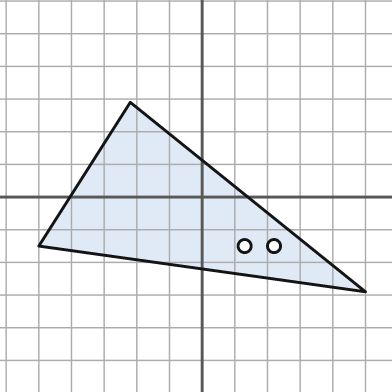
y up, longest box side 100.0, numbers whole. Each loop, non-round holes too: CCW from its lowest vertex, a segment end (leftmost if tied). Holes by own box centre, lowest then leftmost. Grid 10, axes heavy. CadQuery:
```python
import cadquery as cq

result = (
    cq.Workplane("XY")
    .moveTo(50.0, -29.0)
    .lineTo(-22.0, 29.0)
    .lineTo(-50.0, -15.0)
    .close()
    .moveTo(13.0, -15.0)
    .circle(2.0)
    .moveTo(22.0, -15.0)
    .circle(2.0)
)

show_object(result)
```